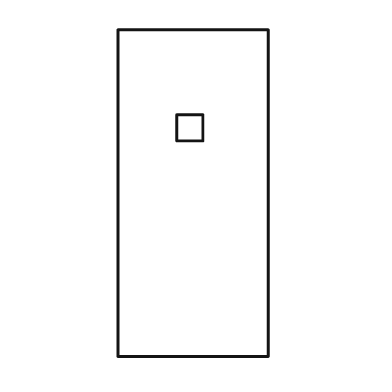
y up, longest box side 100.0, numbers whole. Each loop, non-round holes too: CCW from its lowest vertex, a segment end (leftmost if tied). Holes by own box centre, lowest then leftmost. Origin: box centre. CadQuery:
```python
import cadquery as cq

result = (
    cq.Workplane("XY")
    .moveTo(-23.0, -50.0)
    .lineTo(23.0, -50.0)
    .lineTo(23.0, 50.0)
    .lineTo(-23.0, 50.0)
    .close()
    .moveTo(-5.0, 16.0)
    .lineTo(3.0, 16.0)
    .lineTo(3.0, 24.0)
    .lineTo(-5.0, 24.0)
    .close()
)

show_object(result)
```